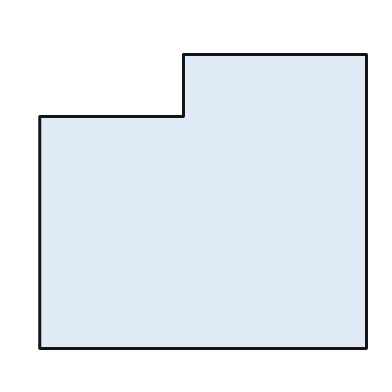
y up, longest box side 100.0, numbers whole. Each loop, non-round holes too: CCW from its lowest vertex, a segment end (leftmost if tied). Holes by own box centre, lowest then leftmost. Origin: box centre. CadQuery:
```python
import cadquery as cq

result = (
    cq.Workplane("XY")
    .moveTo(-50.0, -45.0)
    .lineTo(50.0, -45.0)
    .lineTo(50.0, 45.0)
    .lineTo(-6.0, 45.0)
    .lineTo(-6.0, 26.0)
    .lineTo(-50.0, 26.0)
    .close()
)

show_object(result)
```